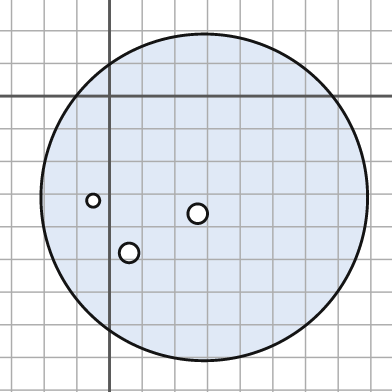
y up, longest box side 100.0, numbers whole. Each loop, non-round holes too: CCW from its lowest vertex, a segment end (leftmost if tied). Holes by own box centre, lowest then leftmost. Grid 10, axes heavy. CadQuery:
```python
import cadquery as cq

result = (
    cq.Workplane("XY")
    .moveTo(29.0, -31.0)
    .circle(50.0)
    .moveTo(6.0, -48.0)
    .circle(3.0)
    .moveTo(27.0, -36.0)
    .circle(3.0)
    .moveTo(-5.0, -32.0)
    .circle(2.0)
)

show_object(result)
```